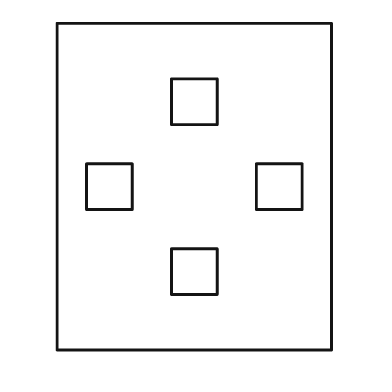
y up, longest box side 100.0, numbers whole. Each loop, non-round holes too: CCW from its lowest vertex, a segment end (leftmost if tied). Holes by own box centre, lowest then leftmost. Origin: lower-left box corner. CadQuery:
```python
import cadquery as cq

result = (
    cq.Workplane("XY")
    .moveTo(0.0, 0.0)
    .lineTo(84.0, 0.0)
    .lineTo(84.0, 100.0)
    .lineTo(0.0, 100.0)
    .close()
    .moveTo(35.0, 17.0)
    .lineTo(49.0, 17.0)
    .lineTo(49.0, 31.0)
    .lineTo(35.0, 31.0)
    .close()
    .moveTo(9.0, 43.0)
    .lineTo(23.0, 43.0)
    .lineTo(23.0, 57.0)
    .lineTo(9.0, 57.0)
    .close()
    .moveTo(61.0, 43.0)
    .lineTo(75.0, 43.0)
    .lineTo(75.0, 57.0)
    .lineTo(61.0, 57.0)
    .close()
    .moveTo(35.0, 69.0)
    .lineTo(49.0, 69.0)
    .lineTo(49.0, 83.0)
    .lineTo(35.0, 83.0)
    .close()
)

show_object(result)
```